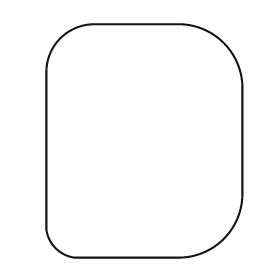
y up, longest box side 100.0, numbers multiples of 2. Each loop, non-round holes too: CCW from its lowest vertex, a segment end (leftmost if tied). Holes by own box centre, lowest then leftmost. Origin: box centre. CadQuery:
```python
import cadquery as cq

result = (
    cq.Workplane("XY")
    .moveTo(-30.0, -50.0)
    .lineTo(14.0, -50.0)
    .threePointArc((34.0, -42.0), (42.0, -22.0))
    .lineTo(42.0, 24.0)
    .threePointArc((34.0, 42.0), (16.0, 50.0))
    .lineTo(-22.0, 50.0)
    .threePointArc((-36.0, 44.0), (-42.0, 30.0))
    .lineTo(-42.0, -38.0)
    .threePointArc((-38.0, -46.0), (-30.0, -50.0))
    .close()
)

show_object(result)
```